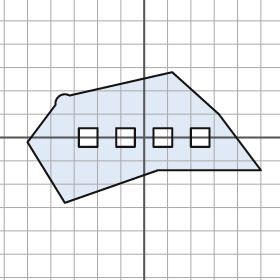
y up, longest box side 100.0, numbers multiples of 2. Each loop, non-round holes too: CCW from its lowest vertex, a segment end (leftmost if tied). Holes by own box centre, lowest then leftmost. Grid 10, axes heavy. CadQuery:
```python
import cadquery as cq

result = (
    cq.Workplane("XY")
    .moveTo(-34.0, -28.0)
    .lineTo(6.0, -14.0)
    .lineTo(50.0, -14.0)
    .lineTo(32.0, 10.0)
    .lineTo(12.0, 28.0)
    .lineTo(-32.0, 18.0)
    .threePointArc((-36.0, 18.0), (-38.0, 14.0))
    .lineTo(-50.0, -2.0)
    .close()
    .moveTo(-28.0, -4.0)
    .lineTo(-20.0, -4.0)
    .lineTo(-20.0, 4.0)
    .lineTo(-28.0, 4.0)
    .close()
    .moveTo(-12.0, -4.0)
    .lineTo(-4.0, -4.0)
    .lineTo(-4.0, 4.0)
    .lineTo(-12.0, 4.0)
    .close()
    .moveTo(4.0, -4.0)
    .lineTo(12.0, -4.0)
    .lineTo(12.0, 4.0)
    .lineTo(4.0, 4.0)
    .close()
    .moveTo(20.0, -4.0)
    .lineTo(28.0, -4.0)
    .lineTo(28.0, 4.0)
    .lineTo(20.0, 4.0)
    .close()
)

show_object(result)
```